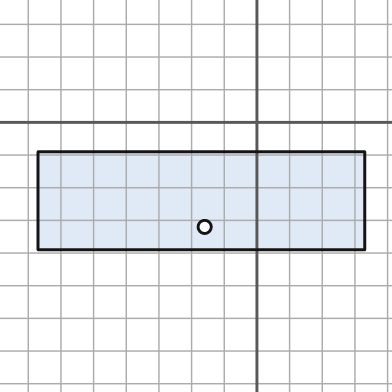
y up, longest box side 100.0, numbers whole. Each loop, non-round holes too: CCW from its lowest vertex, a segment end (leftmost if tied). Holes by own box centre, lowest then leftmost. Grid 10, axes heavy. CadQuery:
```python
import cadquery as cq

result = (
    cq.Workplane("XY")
    .moveTo(-67.0, -39.0)
    .lineTo(33.0, -39.0)
    .lineTo(33.0, -9.0)
    .lineTo(-67.0, -9.0)
    .close()
    .moveTo(-16.0, -32.0)
    .circle(2.0)
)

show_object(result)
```